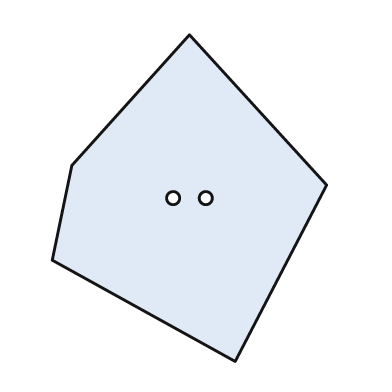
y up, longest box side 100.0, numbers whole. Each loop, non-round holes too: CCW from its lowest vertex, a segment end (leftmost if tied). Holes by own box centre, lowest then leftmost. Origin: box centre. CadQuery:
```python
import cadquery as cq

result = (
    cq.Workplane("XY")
    .moveTo(14.0, -50.0)
    .lineTo(42.0, 4.0)
    .lineTo(0.0, 50.0)
    .lineTo(-36.0, 10.0)
    .lineTo(-42.0, -19.0)
    .close()
    .moveTo(-5.0, 0.0)
    .circle(2.0)
    .moveTo(5.0, 0.0)
    .circle(2.0)
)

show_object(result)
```